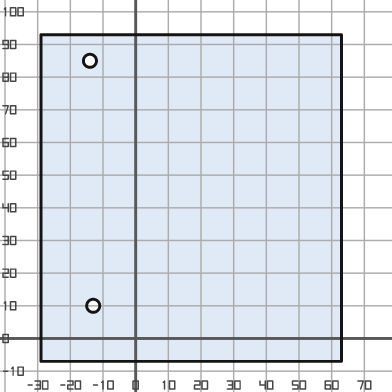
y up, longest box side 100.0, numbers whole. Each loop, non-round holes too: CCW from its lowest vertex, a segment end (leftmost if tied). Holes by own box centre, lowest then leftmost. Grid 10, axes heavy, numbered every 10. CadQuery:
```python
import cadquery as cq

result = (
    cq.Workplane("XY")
    .moveTo(-29.0, -7.0)
    .lineTo(63.0, -7.0)
    .lineTo(63.0, 93.0)
    .lineTo(-29.0, 93.0)
    .close()
    .moveTo(-13.0, 10.0)
    .circle(2.0)
    .moveTo(-14.0, 85.0)
    .circle(2.0)
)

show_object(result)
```